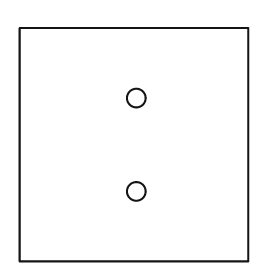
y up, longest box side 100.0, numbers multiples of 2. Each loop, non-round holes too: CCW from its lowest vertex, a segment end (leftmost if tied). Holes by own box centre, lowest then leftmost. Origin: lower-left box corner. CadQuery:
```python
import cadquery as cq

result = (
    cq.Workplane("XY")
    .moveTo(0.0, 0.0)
    .lineTo(98.0, 0.0)
    .lineTo(98.0, 100.0)
    .lineTo(0.0, 100.0)
    .close()
    .moveTo(50.0, 30.0)
    .circle(4.0)
    .moveTo(50.0, 70.0)
    .circle(4.0)
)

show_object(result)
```